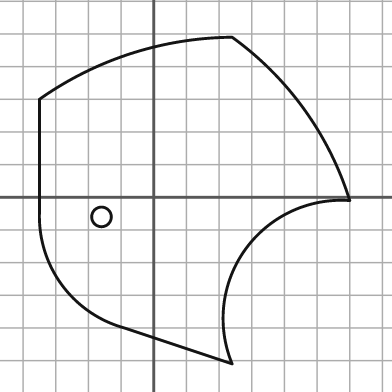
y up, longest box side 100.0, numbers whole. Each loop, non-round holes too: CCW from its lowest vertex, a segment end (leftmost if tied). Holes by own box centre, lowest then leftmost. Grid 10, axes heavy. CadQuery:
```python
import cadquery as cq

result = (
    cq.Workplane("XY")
    .moveTo(24.0, -51.0)
    .threePointArc((28.0, -16.0), (60.0, -1.0))
    .threePointArc((46.0, 27.0), (24.0, 49.0))
    .threePointArc((-7.0, 44.0), (-35.0, 30.0))
    .lineTo(-35.0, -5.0)
    .threePointArc((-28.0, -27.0), (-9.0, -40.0))
    .close()
    .moveTo(-16.0, -6.0)
    .circle(3.0)
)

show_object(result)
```